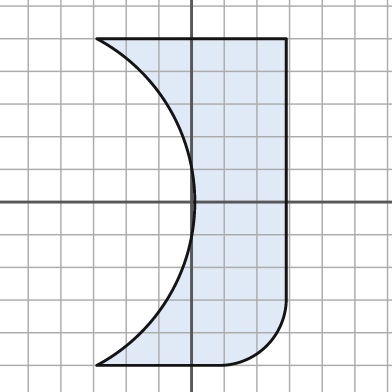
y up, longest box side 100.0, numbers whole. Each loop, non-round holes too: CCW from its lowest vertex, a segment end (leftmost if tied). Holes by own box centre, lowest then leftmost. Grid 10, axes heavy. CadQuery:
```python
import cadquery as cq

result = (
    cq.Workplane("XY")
    .moveTo(-29.0, -50.0)
    .lineTo(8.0, -50.0)
    .threePointArc((23.0, -44.0), (29.0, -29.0))
    .lineTo(29.0, 50.0)
    .lineTo(-29.0, 50.0)
    .threePointArc((1.0, 0.0), (-29.0, -50.0))
    .close()
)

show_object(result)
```